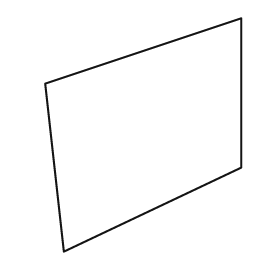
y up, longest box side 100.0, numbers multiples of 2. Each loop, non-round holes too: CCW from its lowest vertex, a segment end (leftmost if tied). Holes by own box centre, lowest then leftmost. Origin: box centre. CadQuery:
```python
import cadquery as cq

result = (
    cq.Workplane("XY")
    .moveTo(-34.0, -50.0)
    .lineTo(42.0, -14.0)
    .lineTo(42.0, 50.0)
    .lineTo(-42.0, 22.0)
    .close()
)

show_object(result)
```